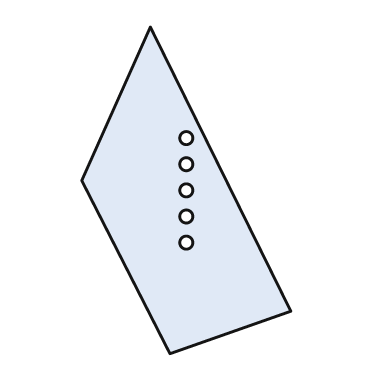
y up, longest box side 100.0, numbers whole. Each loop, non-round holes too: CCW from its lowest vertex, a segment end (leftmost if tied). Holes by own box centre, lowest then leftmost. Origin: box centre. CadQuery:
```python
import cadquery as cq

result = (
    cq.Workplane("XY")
    .moveTo(-5.0, -50.0)
    .lineTo(32.0, -37.0)
    .lineTo(-11.0, 50.0)
    .lineTo(-32.0, 3.0)
    .close()
    .moveTo(0.0, -16.0)
    .circle(2.0)
    .moveTo(0.0, -8.0)
    .circle(2.0)
    .moveTo(0.0, 0.0)
    .circle(2.0)
    .moveTo(0.0, 8.0)
    .circle(2.0)
    .moveTo(0.0, 16.0)
    .circle(2.0)
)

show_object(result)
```